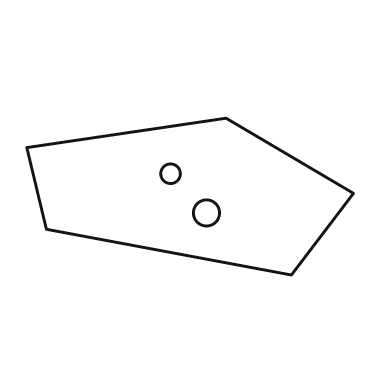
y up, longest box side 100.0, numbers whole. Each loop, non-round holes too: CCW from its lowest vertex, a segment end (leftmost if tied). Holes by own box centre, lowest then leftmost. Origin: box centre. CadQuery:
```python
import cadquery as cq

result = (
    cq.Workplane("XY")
    .moveTo(31.0, -24.0)
    .lineTo(50.0, 1.0)
    .lineTo(11.0, 24.0)
    .lineTo(-50.0, 15.0)
    .lineTo(-44.0, -10.0)
    .close()
    .moveTo(5.0, -5.0)
    .circle(4.0)
    .moveTo(-6.0, 7.0)
    .circle(3.0)
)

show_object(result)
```